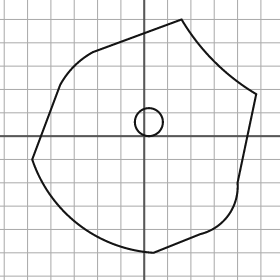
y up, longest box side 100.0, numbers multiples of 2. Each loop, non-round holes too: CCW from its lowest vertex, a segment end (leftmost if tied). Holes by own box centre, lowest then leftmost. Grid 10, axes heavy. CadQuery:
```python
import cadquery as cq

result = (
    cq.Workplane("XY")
    .moveTo(4.0, -50.0)
    .lineTo(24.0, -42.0)
    .threePointArc((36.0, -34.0), (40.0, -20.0))
    .lineTo(48.0, 18.0)
    .threePointArc((30.0, 32.0), (16.0, 50.0))
    .lineTo(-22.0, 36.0)
    .threePointArc((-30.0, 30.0), (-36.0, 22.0))
    .lineTo(-48.0, -10.0)
    .threePointArc((-28.0, -38.0), (4.0, -50.0))
    .close()
    .moveTo(2.0, 6.0)
    .circle(6.0)
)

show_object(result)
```